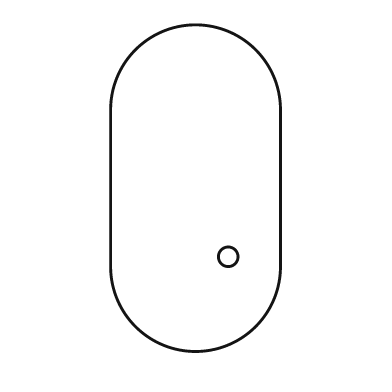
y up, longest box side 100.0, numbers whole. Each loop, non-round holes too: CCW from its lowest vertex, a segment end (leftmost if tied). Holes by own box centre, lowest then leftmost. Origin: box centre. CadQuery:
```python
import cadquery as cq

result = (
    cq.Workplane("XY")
    .moveTo(-26.0, -24.0)
    .threePointArc((0.0, -50.0), (26.0, -24.0))
    .lineTo(26.0, 24.0)
    .threePointArc((0.0, 50.0), (-26.0, 24.0))
    .close()
    .moveTo(10.0, -21.0)
    .circle(3.0)
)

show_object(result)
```